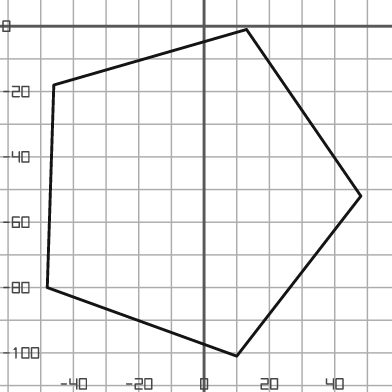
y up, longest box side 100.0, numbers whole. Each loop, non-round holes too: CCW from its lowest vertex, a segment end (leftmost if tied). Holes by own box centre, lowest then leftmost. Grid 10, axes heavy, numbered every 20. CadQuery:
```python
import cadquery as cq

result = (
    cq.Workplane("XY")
    .moveTo(10.0, -101.0)
    .lineTo(48.0, -52.0)
    .lineTo(13.0, -1.0)
    .lineTo(-46.0, -18.0)
    .lineTo(-48.0, -80.0)
    .close()
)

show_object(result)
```